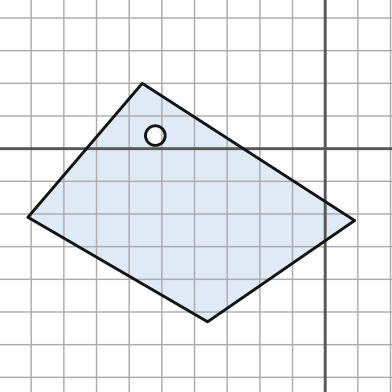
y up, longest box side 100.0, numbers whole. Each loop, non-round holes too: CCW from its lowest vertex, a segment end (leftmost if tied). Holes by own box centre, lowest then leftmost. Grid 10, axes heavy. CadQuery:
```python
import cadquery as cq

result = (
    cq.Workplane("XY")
    .moveTo(-36.0, -53.0)
    .lineTo(9.0, -22.0)
    .lineTo(-56.0, 20.0)
    .lineTo(-91.0, -21.0)
    .close()
    .moveTo(-52.0, 4.0)
    .circle(3.0)
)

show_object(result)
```